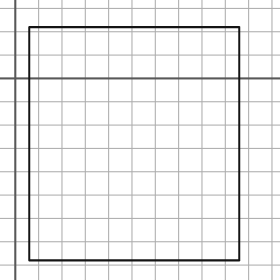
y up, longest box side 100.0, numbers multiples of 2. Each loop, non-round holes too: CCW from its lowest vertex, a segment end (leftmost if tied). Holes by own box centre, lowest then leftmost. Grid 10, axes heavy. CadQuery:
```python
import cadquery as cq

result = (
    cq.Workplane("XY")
    .moveTo(6.0, -78.0)
    .lineTo(96.0, -78.0)
    .lineTo(96.0, 22.0)
    .lineTo(6.0, 22.0)
    .close()
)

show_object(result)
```